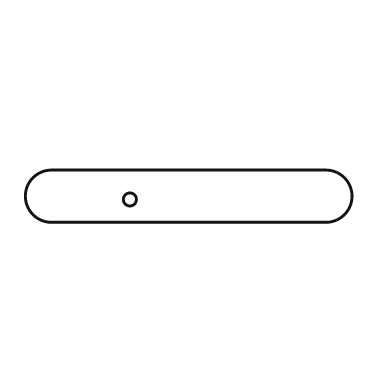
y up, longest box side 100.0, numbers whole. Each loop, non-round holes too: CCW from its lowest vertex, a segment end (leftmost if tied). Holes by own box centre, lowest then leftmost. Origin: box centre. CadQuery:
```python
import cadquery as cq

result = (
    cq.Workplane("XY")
    .moveTo(-42.0, -8.0)
    .lineTo(42.0, -8.0)
    .threePointArc((50.0, 0.0), (42.0, 8.0))
    .lineTo(-42.0, 8.0)
    .threePointArc((-50.0, 0.0), (-42.0, -8.0))
    .close()
    .moveTo(-18.0, -1.0)
    .circle(2.0)
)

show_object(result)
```